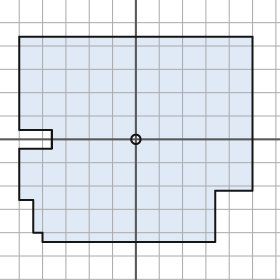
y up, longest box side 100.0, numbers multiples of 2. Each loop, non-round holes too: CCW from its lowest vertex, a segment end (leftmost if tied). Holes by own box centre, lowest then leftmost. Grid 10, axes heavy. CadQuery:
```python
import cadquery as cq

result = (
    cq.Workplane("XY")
    .moveTo(-40.0, -44.0)
    .lineTo(34.0, -44.0)
    .lineTo(34.0, -22.0)
    .lineTo(50.0, -22.0)
    .lineTo(50.0, 44.0)
    .lineTo(-50.0, 44.0)
    .lineTo(-50.0, 4.0)
    .lineTo(-36.0, 4.0)
    .lineTo(-36.0, -4.0)
    .lineTo(-50.0, -4.0)
    .lineTo(-50.0, -26.0)
    .lineTo(-44.0, -26.0)
    .lineTo(-44.0, -40.0)
    .lineTo(-40.0, -40.0)
    .close()
    .moveTo(0.0, 0.0)
    .circle(2.0)
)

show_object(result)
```